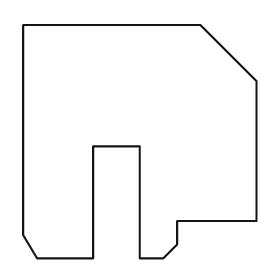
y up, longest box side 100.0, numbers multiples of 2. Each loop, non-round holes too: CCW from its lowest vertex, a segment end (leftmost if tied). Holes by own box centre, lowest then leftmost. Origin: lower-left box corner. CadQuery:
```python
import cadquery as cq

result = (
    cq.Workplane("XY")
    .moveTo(6.0, 0.0)
    .lineTo(30.0, 0.0)
    .lineTo(30.0, 48.0)
    .lineTo(50.0, 48.0)
    .lineTo(50.0, 0.0)
    .lineTo(60.0, 0.0)
    .lineTo(66.0, 6.0)
    .lineTo(66.0, 16.0)
    .lineTo(100.0, 16.0)
    .lineTo(100.0, 76.0)
    .lineTo(76.0, 100.0)
    .lineTo(0.0, 100.0)
    .lineTo(0.0, 10.0)
    .close()
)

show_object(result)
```